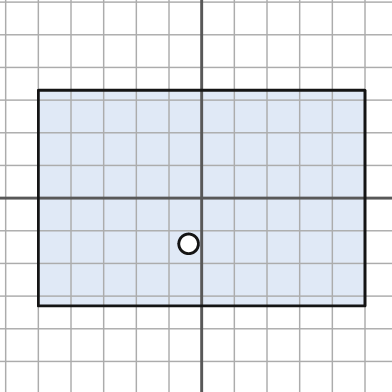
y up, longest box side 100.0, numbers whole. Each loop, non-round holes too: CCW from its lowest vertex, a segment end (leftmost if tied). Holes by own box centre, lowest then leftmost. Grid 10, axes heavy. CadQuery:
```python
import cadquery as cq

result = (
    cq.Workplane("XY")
    .moveTo(-50.0, -33.0)
    .lineTo(50.0, -33.0)
    .lineTo(50.0, 33.0)
    .lineTo(-50.0, 33.0)
    .close()
    .moveTo(-4.0, -14.0)
    .circle(3.0)
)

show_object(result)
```